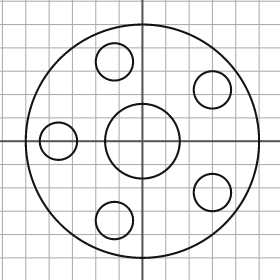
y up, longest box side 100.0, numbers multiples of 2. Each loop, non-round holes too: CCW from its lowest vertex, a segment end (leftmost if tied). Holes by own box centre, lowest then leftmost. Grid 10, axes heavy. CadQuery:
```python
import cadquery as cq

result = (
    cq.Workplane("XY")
    .moveTo(0.0, 0.0)
    .circle(50.0)
    .moveTo(-12.0, -34.0)
    .circle(8.0)
    .moveTo(30.0, -22.0)
    .circle(8.0)
    .moveTo(-36.0, 0.0)
    .circle(8.0)
    .moveTo(0.0, 0.0)
    .circle(16.0)
    .moveTo(30.0, 22.0)
    .circle(8.0)
    .moveTo(-12.0, 34.0)
    .circle(8.0)
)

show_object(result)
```